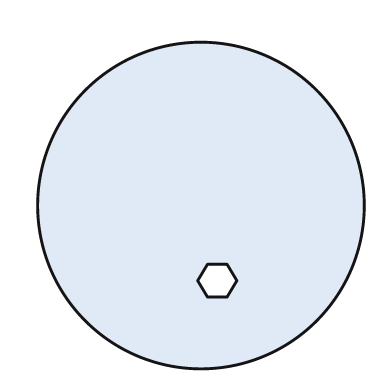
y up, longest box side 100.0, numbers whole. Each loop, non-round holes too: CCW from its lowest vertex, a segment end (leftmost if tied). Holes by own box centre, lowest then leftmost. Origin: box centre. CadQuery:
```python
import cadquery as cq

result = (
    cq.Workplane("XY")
    .moveTo(0.0, 0.0)
    .circle(50.0)
    .moveTo(2.0, -28.0)
    .lineTo(8.0, -28.0)
    .lineTo(11.0, -23.0)
    .lineTo(8.0, -18.0)
    .lineTo(2.0, -18.0)
    .lineTo(-1.0, -23.0)
    .close()
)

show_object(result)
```